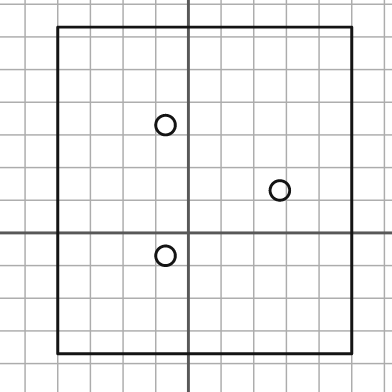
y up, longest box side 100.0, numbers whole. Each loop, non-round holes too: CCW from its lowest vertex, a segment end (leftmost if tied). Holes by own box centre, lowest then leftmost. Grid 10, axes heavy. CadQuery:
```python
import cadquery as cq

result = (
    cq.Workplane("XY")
    .moveTo(-40.0, -37.0)
    .lineTo(50.0, -37.0)
    .lineTo(50.0, 63.0)
    .lineTo(-40.0, 63.0)
    .close()
    .moveTo(-7.0, -7.0)
    .circle(3.0)
    .moveTo(28.0, 13.0)
    .circle(3.0)
    .moveTo(-7.0, 33.0)
    .circle(3.0)
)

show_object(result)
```